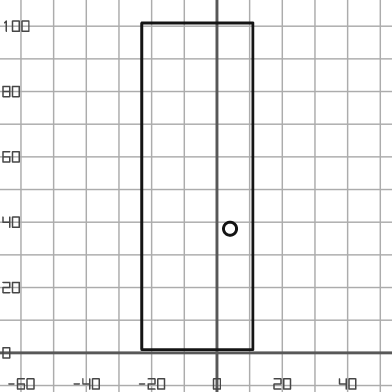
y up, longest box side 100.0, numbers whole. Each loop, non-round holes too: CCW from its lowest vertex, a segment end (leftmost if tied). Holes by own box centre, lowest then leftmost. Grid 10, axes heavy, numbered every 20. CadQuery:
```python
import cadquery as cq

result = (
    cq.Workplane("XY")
    .moveTo(-23.0, 1.0)
    .lineTo(11.0, 1.0)
    .lineTo(11.0, 101.0)
    .lineTo(-23.0, 101.0)
    .close()
    .moveTo(4.0, 38.0)
    .circle(2.0)
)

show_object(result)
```